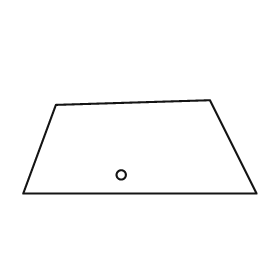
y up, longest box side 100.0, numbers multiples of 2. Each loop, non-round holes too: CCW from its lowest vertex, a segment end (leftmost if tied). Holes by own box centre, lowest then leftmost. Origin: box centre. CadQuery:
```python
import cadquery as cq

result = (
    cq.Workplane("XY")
    .moveTo(-50.0, -20.0)
    .lineTo(50.0, -20.0)
    .lineTo(30.0, 20.0)
    .lineTo(-36.0, 18.0)
    .close()
    .moveTo(-8.0, -12.0)
    .circle(2.0)
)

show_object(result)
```